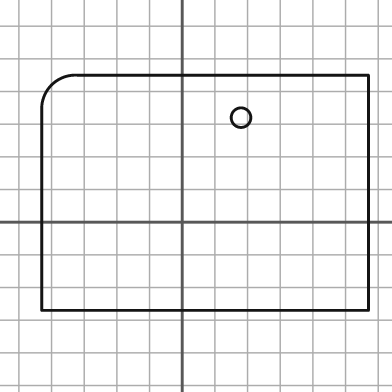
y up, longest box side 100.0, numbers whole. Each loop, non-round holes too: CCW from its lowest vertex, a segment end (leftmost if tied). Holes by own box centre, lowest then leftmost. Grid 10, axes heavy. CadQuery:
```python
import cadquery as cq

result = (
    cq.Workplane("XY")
    .moveTo(-43.0, -27.0)
    .lineTo(57.0, -27.0)
    .lineTo(57.0, 45.0)
    .lineTo(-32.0, 45.0)
    .threePointArc((-40.0, 42.0), (-43.0, 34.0))
    .close()
    .moveTo(18.0, 32.0)
    .circle(3.0)
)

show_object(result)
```